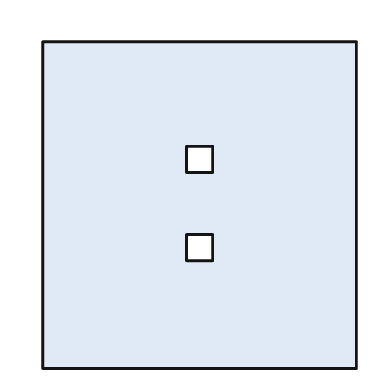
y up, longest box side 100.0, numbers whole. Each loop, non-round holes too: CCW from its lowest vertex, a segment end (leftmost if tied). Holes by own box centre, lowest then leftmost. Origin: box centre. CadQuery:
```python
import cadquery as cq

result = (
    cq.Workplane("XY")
    .moveTo(-48.0, -50.0)
    .lineTo(48.0, -50.0)
    .lineTo(48.0, 50.0)
    .lineTo(-48.0, 50.0)
    .close()
    .moveTo(-4.0, -17.0)
    .lineTo(4.0, -17.0)
    .lineTo(4.0, -9.0)
    .lineTo(-4.0, -9.0)
    .close()
    .moveTo(-4.0, 10.0)
    .lineTo(4.0, 10.0)
    .lineTo(4.0, 18.0)
    .lineTo(-4.0, 18.0)
    .close()
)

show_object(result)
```